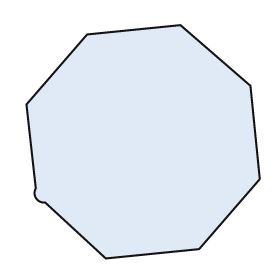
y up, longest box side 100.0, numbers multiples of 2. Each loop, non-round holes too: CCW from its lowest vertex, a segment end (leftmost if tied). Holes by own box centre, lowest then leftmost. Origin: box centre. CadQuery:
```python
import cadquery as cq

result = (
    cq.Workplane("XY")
    .moveTo(-16.0, -50.0)
    .lineTo(24.0, -46.0)
    .lineTo(50.0, -16.0)
    .lineTo(46.0, 24.0)
    .lineTo(16.0, 50.0)
    .lineTo(-24.0, 46.0)
    .lineTo(-50.0, 16.0)
    .lineTo(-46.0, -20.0)
    .threePointArc((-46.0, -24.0), (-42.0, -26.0))
    .close()
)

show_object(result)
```